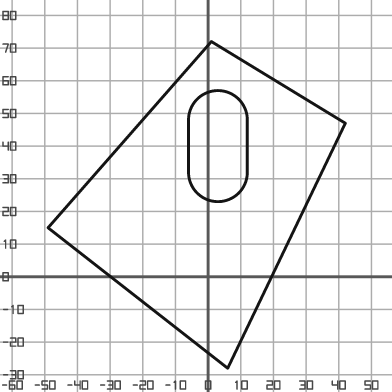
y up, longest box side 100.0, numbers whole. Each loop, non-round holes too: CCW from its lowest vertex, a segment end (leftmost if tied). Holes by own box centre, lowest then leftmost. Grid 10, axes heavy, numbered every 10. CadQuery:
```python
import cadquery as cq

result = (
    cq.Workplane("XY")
    .moveTo(6.0, -28.0)
    .lineTo(42.0, 47.0)
    .lineTo(1.0, 72.0)
    .lineTo(-49.0, 15.0)
    .close()
    .moveTo(-6.0, 32.0)
    .threePointArc((3.0, 23.0), (12.0, 32.0))
    .lineTo(12.0, 48.0)
    .threePointArc((3.0, 57.0), (-6.0, 48.0))
    .close()
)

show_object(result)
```